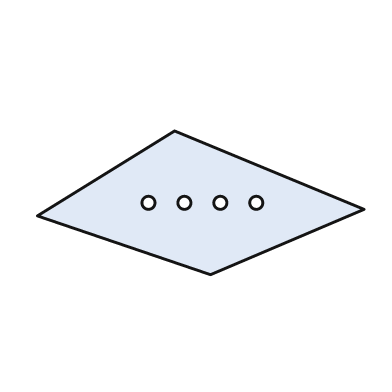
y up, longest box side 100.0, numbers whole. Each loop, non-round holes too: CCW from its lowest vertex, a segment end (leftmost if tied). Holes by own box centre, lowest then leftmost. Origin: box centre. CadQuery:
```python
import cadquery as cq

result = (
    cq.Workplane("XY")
    .moveTo(3.0, -22.0)
    .lineTo(50.0, -2.0)
    .lineTo(-8.0, 22.0)
    .lineTo(-50.0, -4.0)
    .close()
    .moveTo(-16.0, 0.0)
    .circle(2.0)
    .moveTo(-5.0, 0.0)
    .circle(2.0)
    .moveTo(6.0, 0.0)
    .circle(2.0)
    .moveTo(17.0, 0.0)
    .circle(2.0)
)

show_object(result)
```